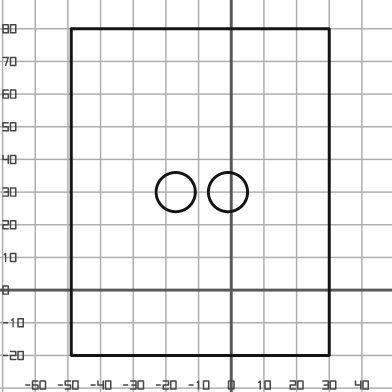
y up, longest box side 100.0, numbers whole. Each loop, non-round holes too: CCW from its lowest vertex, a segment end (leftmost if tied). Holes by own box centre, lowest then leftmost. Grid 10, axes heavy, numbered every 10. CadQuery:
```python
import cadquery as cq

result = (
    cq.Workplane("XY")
    .moveTo(-49.0, -20.0)
    .lineTo(30.0, -20.0)
    .lineTo(30.0, 80.0)
    .lineTo(-49.0, 80.0)
    .close()
    .moveTo(-17.0, 30.0)
    .circle(6.0)
    .moveTo(-1.0, 30.0)
    .circle(6.0)
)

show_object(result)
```